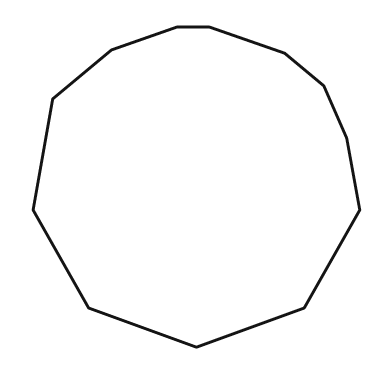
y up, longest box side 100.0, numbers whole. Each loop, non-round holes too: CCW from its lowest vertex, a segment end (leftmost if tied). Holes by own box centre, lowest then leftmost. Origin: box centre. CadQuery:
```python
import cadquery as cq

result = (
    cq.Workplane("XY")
    .moveTo(0.0, -49.0)
    .lineTo(33.0, -37.0)
    .lineTo(50.0, -7.0)
    .lineTo(46.0, 15.0)
    .lineTo(39.0, 31.0)
    .lineTo(27.0, 41.0)
    .lineTo(4.0, 49.0)
    .lineTo(-6.0, 49.0)
    .lineTo(-26.0, 42.0)
    .lineTo(-44.0, 27.0)
    .lineTo(-50.0, -7.0)
    .lineTo(-33.0, -37.0)
    .close()
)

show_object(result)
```